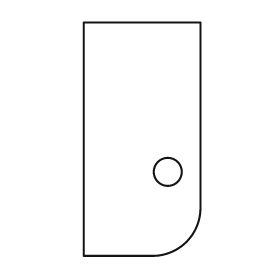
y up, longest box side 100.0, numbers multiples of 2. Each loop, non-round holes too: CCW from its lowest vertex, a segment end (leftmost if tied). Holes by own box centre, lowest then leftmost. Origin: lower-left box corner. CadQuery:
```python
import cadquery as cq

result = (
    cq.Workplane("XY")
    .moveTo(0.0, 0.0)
    .lineTo(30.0, 0.0)
    .threePointArc((44.0, 6.0), (50.0, 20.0))
    .lineTo(50.0, 100.0)
    .lineTo(0.0, 100.0)
    .close()
    .moveTo(36.0, 36.0)
    .circle(6.0)
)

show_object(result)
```